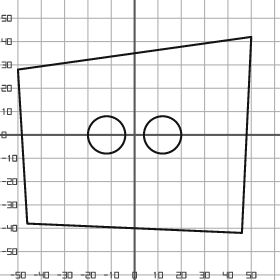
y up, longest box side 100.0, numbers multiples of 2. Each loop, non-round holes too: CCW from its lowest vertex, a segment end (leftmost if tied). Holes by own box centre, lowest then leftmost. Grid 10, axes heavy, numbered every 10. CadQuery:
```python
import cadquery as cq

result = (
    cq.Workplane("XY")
    .moveTo(46.0, -42.0)
    .lineTo(50.0, 42.0)
    .lineTo(-50.0, 28.0)
    .lineTo(-46.0, -38.0)
    .close()
    .moveTo(-12.0, 0.0)
    .circle(8.0)
    .moveTo(12.0, 0.0)
    .circle(8.0)
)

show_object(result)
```